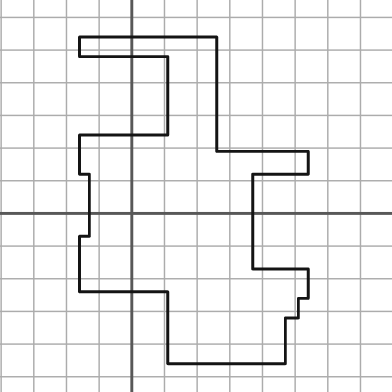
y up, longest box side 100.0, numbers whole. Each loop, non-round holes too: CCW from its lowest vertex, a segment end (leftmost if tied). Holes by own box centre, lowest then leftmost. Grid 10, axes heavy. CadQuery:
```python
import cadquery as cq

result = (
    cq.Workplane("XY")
    .moveTo(11.0, -46.0)
    .lineTo(47.0, -46.0)
    .lineTo(47.0, -32.0)
    .lineTo(51.0, -32.0)
    .lineTo(51.0, -26.0)
    .lineTo(54.0, -26.0)
    .lineTo(54.0, -17.0)
    .lineTo(37.0, -17.0)
    .lineTo(37.0, 12.0)
    .lineTo(54.0, 12.0)
    .lineTo(54.0, 19.0)
    .lineTo(26.0, 19.0)
    .lineTo(26.0, 54.0)
    .lineTo(-16.0, 54.0)
    .lineTo(-16.0, 48.0)
    .lineTo(11.0, 48.0)
    .lineTo(11.0, 24.0)
    .lineTo(-16.0, 24.0)
    .lineTo(-16.0, 12.0)
    .lineTo(-13.0, 12.0)
    .lineTo(-13.0, -7.0)
    .lineTo(-16.0, -7.0)
    .lineTo(-16.0, -24.0)
    .lineTo(11.0, -24.0)
    .close()
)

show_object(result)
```